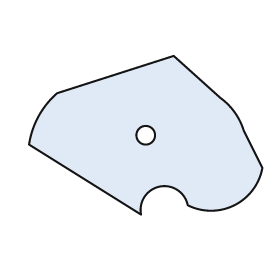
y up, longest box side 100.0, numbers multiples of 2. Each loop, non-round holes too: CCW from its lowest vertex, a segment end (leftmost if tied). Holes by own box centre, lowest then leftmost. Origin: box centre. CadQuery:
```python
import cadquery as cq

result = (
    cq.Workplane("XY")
    .moveTo(-2.0, -34.0)
    .threePointArc((6.0, -22.0), (18.0, -30.0))
    .threePointArc((38.0, -30.0), (50.0, -14.0))
    .lineTo(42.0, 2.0)
    .threePointArc((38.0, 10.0), (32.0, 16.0))
    .lineTo(12.0, 34.0)
    .lineTo(-38.0, 18.0)
    .threePointArc((-46.0, 8.0), (-50.0, -4.0))
    .close()
    .moveTo(0.0, 0.0)
    .circle(4.0)
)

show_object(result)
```